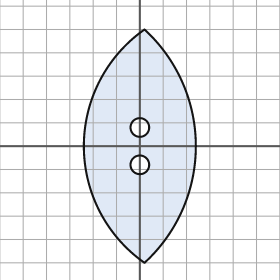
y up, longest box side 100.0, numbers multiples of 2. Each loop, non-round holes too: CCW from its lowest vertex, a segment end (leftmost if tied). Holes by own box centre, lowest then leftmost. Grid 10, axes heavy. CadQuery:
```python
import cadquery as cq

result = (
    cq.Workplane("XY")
    .moveTo(2.0, -50.0)
    .threePointArc((24.0, 0.0), (2.0, 50.0))
    .threePointArc((-24.0, 0.0), (2.0, -50.0))
    .close()
    .moveTo(0.0, -8.0)
    .circle(4.0)
    .moveTo(0.0, 8.0)
    .circle(4.0)
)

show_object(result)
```